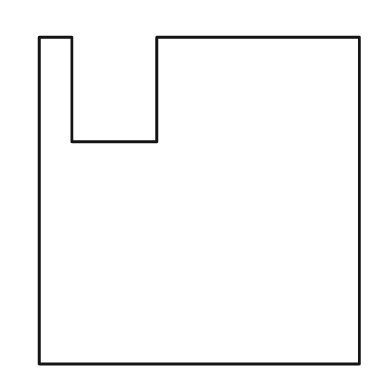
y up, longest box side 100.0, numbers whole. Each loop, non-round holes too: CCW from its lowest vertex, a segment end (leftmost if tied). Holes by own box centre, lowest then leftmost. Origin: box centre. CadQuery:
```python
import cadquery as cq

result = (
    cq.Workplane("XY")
    .moveTo(-49.0, -50.0)
    .lineTo(49.0, -50.0)
    .lineTo(49.0, 50.0)
    .lineTo(-13.0, 50.0)
    .lineTo(-13.0, 18.0)
    .lineTo(-39.0, 18.0)
    .lineTo(-39.0, 50.0)
    .lineTo(-49.0, 50.0)
    .close()
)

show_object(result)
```